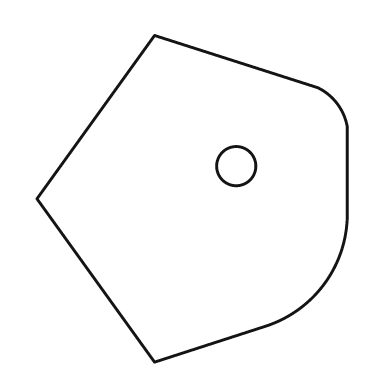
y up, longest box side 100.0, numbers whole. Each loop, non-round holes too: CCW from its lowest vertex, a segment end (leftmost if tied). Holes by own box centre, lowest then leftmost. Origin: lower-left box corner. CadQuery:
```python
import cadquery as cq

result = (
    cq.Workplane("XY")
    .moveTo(36.0, 0.0)
    .lineTo(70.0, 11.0)
    .threePointArc((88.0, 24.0), (95.0, 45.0))
    .lineTo(95.0, 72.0)
    .threePointArc((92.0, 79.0), (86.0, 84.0))
    .lineTo(36.0, 100.0)
    .lineTo(0.0, 50.0)
    .close()
    .moveTo(61.0, 60.0)
    .circle(6.0)
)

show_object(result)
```